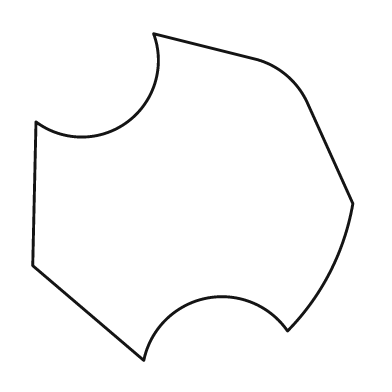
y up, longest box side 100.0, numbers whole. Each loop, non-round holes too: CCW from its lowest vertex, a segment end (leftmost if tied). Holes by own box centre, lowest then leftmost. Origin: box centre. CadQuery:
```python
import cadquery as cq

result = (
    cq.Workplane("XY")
    .moveTo(-15.0, -50.0)
    .threePointArc((4.0, -31.0), (29.0, -41.0))
    .threePointArc((42.0, -23.0), (49.0, -2.0))
    .lineTo(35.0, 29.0)
    .threePointArc((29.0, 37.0), (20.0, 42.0))
    .lineTo(-12.0, 50.0)
    .threePointArc((-20.0, 23.0), (-48.0, 23.0))
    .lineTo(-49.0, -21.0)
    .close()
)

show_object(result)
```